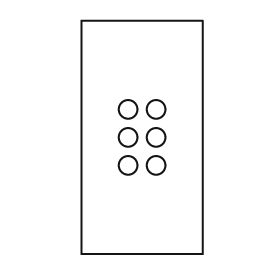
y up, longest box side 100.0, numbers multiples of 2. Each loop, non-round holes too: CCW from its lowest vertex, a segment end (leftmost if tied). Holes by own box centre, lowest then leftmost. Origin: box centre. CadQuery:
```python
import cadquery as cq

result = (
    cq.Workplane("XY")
    .moveTo(-26.0, -50.0)
    .lineTo(26.0, -50.0)
    .lineTo(26.0, 50.0)
    .lineTo(-26.0, 50.0)
    .close()
    .moveTo(-6.0, -12.0)
    .circle(4.0)
    .moveTo(6.0, -12.0)
    .circle(4.0)
    .moveTo(-6.0, 0.0)
    .circle(4.0)
    .moveTo(6.0, 0.0)
    .circle(4.0)
    .moveTo(-6.0, 12.0)
    .circle(4.0)
    .moveTo(6.0, 12.0)
    .circle(4.0)
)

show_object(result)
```